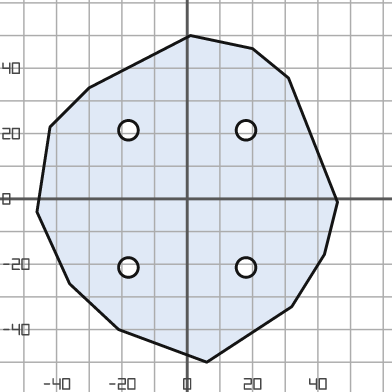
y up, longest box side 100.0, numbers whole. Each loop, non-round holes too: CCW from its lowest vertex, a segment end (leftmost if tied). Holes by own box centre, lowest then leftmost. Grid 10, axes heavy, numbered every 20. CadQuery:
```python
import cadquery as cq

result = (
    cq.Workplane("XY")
    .moveTo(6.0, -50.0)
    .lineTo(32.0, -33.0)
    .lineTo(42.0, -17.0)
    .lineTo(46.0, -1.0)
    .lineTo(31.0, 37.0)
    .lineTo(20.0, 46.0)
    .lineTo(1.0, 50.0)
    .lineTo(-30.0, 34.0)
    .lineTo(-42.0, 22.0)
    .lineTo(-46.0, -4.0)
    .lineTo(-36.0, -26.0)
    .lineTo(-21.0, -40.0)
    .close()
    .moveTo(-18.0, -21.0)
    .circle(3.0)
    .moveTo(18.0, -21.0)
    .circle(3.0)
    .moveTo(-18.0, 21.0)
    .circle(3.0)
    .moveTo(18.0, 21.0)
    .circle(3.0)
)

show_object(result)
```